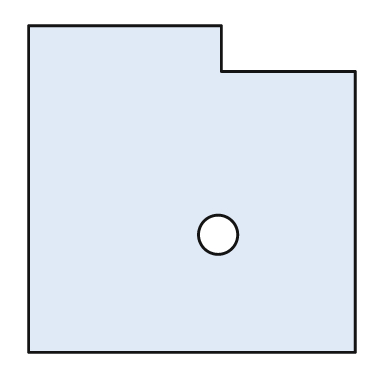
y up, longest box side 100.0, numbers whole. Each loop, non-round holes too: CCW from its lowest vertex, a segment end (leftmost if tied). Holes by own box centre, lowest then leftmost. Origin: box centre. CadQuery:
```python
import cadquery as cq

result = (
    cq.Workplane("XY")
    .moveTo(-50.0, -50.0)
    .lineTo(50.0, -50.0)
    .lineTo(50.0, 36.0)
    .lineTo(9.0, 36.0)
    .lineTo(9.0, 50.0)
    .lineTo(-50.0, 50.0)
    .close()
    .moveTo(8.0, -14.0)
    .circle(6.0)
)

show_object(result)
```